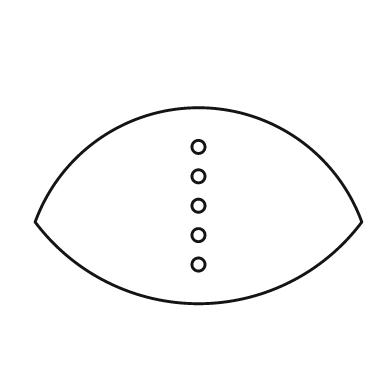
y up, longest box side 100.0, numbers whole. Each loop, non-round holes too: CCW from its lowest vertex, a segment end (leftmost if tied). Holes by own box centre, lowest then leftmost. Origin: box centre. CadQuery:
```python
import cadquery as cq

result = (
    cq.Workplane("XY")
    .moveTo(-50.0, -5.0)
    .threePointArc((0.0, -30.0), (50.0, -5.0))
    .threePointArc((0.0, 30.0), (-50.0, -5.0))
    .close()
    .moveTo(0.0, -18.0)
    .circle(2.0)
    .moveTo(0.0, -9.0)
    .circle(2.0)
    .moveTo(0.0, 0.0)
    .circle(2.0)
    .moveTo(0.0, 9.0)
    .circle(2.0)
    .moveTo(0.0, 18.0)
    .circle(2.0)
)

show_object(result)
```